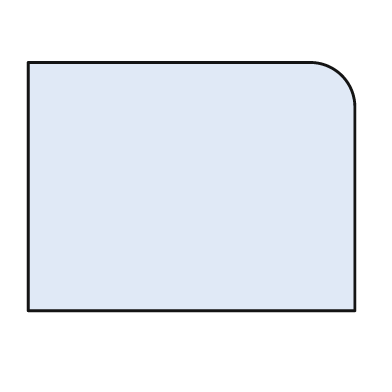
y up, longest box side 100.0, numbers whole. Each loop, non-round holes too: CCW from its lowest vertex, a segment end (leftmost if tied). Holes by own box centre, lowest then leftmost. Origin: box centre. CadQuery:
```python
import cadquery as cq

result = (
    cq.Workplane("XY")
    .moveTo(-50.0, -38.0)
    .lineTo(50.0, -38.0)
    .lineTo(50.0, 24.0)
    .threePointArc((46.0, 34.0), (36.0, 38.0))
    .lineTo(-50.0, 38.0)
    .close()
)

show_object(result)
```